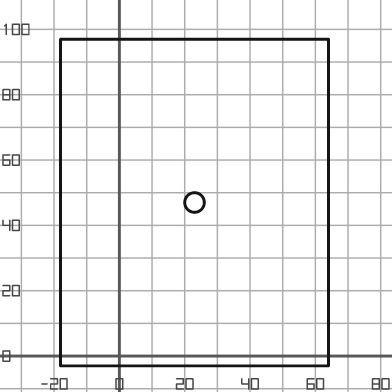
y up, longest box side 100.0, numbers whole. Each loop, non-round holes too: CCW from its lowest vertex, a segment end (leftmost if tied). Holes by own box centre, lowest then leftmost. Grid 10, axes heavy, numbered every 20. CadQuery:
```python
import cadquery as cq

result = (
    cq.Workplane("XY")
    .moveTo(-18.0, -3.0)
    .lineTo(64.0, -3.0)
    .lineTo(64.0, 97.0)
    .lineTo(-18.0, 97.0)
    .close()
    .moveTo(23.0, 47.0)
    .circle(3.0)
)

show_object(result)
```